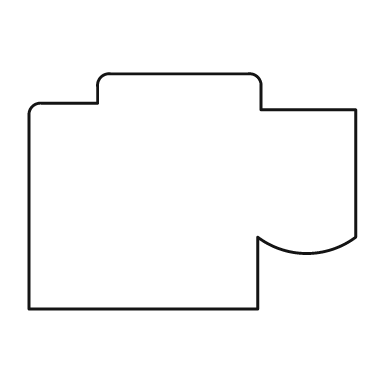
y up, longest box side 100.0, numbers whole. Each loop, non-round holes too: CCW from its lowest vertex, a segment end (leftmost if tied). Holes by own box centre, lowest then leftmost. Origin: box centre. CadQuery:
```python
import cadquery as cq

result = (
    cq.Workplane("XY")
    .moveTo(-50.0, -36.0)
    .lineTo(20.0, -36.0)
    .lineTo(20.0, -14.0)
    .threePointArc((35.0, -19.0), (50.0, -14.0))
    .lineTo(50.0, 25.0)
    .lineTo(21.0, 25.0)
    .lineTo(21.0, 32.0)
    .threePointArc((20.0, 35.0), (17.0, 36.0))
    .lineTo(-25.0, 36.0)
    .threePointArc((-28.0, 35.0), (-29.0, 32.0))
    .lineTo(-29.0, 27.0)
    .lineTo(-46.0, 27.0)
    .threePointArc((-49.0, 26.0), (-50.0, 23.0))
    .close()
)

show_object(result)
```